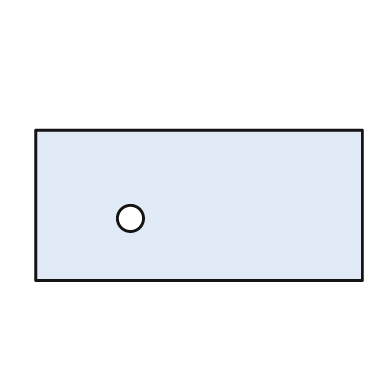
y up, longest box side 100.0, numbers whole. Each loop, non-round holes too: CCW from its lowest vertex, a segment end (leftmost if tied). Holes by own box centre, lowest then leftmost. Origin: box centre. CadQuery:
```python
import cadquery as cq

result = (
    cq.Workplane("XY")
    .moveTo(-50.0, -23.0)
    .lineTo(50.0, -23.0)
    .lineTo(50.0, 23.0)
    .lineTo(-50.0, 23.0)
    .close()
    .moveTo(-21.0, -4.0)
    .circle(4.0)
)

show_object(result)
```